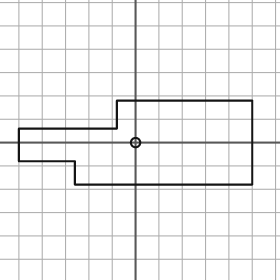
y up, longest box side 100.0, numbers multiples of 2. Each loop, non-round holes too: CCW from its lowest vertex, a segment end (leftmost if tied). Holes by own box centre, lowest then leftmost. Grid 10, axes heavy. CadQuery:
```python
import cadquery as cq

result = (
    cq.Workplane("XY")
    .moveTo(-26.0, -18.0)
    .lineTo(50.0, -18.0)
    .lineTo(50.0, 18.0)
    .lineTo(-8.0, 18.0)
    .lineTo(-8.0, 6.0)
    .lineTo(-50.0, 6.0)
    .lineTo(-50.0, -8.0)
    .lineTo(-26.0, -8.0)
    .close()
    .moveTo(0.0, 0.0)
    .circle(2.0)
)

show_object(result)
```